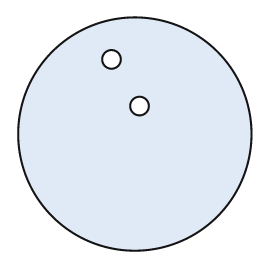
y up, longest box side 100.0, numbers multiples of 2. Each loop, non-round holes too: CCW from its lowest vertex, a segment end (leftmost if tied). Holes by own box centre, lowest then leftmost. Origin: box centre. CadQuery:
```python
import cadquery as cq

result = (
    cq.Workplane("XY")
    .moveTo(0.0, 0.0)
    .circle(50.0)
    .moveTo(2.0, 12.0)
    .circle(4.0)
    .moveTo(-10.0, 32.0)
    .circle(4.0)
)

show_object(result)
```